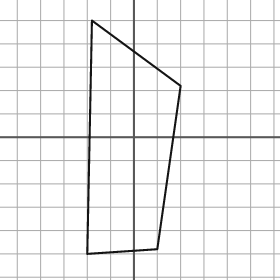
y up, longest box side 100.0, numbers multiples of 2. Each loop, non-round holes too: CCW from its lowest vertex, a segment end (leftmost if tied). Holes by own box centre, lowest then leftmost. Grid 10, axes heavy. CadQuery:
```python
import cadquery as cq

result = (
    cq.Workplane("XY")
    .moveTo(-20.0, -50.0)
    .lineTo(10.0, -48.0)
    .lineTo(20.0, 22.0)
    .lineTo(-18.0, 50.0)
    .close()
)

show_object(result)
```